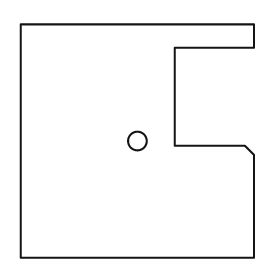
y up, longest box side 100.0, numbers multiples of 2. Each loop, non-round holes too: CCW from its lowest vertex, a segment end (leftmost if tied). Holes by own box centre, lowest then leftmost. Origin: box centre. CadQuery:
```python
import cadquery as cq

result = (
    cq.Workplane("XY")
    .moveTo(-50.0, -50.0)
    .lineTo(50.0, -50.0)
    .lineTo(50.0, -6.0)
    .lineTo(46.0, -2.0)
    .lineTo(16.0, -2.0)
    .lineTo(16.0, 40.0)
    .lineTo(50.0, 40.0)
    .lineTo(50.0, 50.0)
    .lineTo(-50.0, 50.0)
    .close()
    .moveTo(0.0, 0.0)
    .circle(4.0)
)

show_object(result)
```